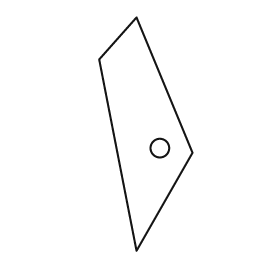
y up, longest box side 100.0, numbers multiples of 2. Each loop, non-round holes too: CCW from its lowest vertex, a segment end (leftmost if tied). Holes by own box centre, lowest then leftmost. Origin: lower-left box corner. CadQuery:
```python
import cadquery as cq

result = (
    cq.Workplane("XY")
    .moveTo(16.0, 0.0)
    .lineTo(40.0, 42.0)
    .lineTo(16.0, 100.0)
    .lineTo(0.0, 82.0)
    .close()
    .moveTo(26.0, 44.0)
    .circle(4.0)
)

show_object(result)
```